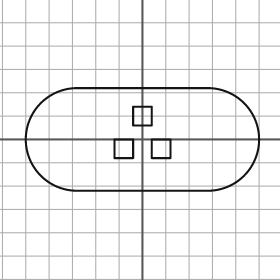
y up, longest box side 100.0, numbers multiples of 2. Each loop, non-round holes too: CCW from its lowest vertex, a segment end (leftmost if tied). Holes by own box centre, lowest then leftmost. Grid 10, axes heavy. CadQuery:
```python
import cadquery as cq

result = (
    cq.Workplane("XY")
    .moveTo(-28.0, -22.0)
    .lineTo(28.0, -22.0)
    .threePointArc((50.0, 0.0), (28.0, 22.0))
    .lineTo(-28.0, 22.0)
    .threePointArc((-50.0, 0.0), (-28.0, -22.0))
    .close()
    .moveTo(-12.0, -8.0)
    .lineTo(-4.0, -8.0)
    .lineTo(-4.0, 0.0)
    .lineTo(-12.0, 0.0)
    .close()
    .moveTo(4.0, -8.0)
    .lineTo(12.0, -8.0)
    .lineTo(12.0, 0.0)
    .lineTo(4.0, 0.0)
    .close()
    .moveTo(-4.0, 6.0)
    .lineTo(4.0, 6.0)
    .lineTo(4.0, 14.0)
    .lineTo(-4.0, 14.0)
    .close()
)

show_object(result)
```